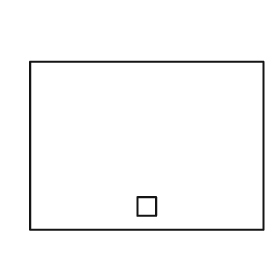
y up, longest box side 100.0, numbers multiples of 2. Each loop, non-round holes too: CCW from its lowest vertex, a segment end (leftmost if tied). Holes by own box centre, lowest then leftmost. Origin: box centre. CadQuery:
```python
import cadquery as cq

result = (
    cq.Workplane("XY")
    .moveTo(-50.0, -36.0)
    .lineTo(50.0, -36.0)
    .lineTo(50.0, 36.0)
    .lineTo(-50.0, 36.0)
    .close()
    .moveTo(-4.0, -30.0)
    .lineTo(4.0, -30.0)
    .lineTo(4.0, -22.0)
    .lineTo(-4.0, -22.0)
    .close()
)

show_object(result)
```